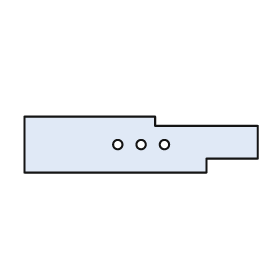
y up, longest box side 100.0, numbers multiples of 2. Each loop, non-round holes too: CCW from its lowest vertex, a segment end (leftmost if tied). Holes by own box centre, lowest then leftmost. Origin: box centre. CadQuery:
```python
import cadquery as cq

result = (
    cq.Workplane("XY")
    .moveTo(-50.0, -12.0)
    .lineTo(28.0, -12.0)
    .lineTo(28.0, -6.0)
    .lineTo(50.0, -6.0)
    .lineTo(50.0, 8.0)
    .lineTo(6.0, 8.0)
    .lineTo(6.0, 12.0)
    .lineTo(-50.0, 12.0)
    .close()
    .moveTo(-10.0, 0.0)
    .circle(2.0)
    .moveTo(0.0, 0.0)
    .circle(2.0)
    .moveTo(10.0, 0.0)
    .circle(2.0)
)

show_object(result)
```